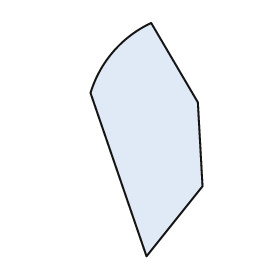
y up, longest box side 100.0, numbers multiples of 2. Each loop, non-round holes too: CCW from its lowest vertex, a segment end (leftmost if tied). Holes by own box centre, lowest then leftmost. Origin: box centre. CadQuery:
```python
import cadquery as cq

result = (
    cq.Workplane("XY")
    .moveTo(0.0, -50.0)
    .lineTo(24.0, -20.0)
    .lineTo(22.0, 16.0)
    .lineTo(2.0, 50.0)
    .threePointArc((-14.0, 38.0), (-24.0, 20.0))
    .close()
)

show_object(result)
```